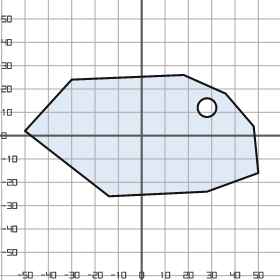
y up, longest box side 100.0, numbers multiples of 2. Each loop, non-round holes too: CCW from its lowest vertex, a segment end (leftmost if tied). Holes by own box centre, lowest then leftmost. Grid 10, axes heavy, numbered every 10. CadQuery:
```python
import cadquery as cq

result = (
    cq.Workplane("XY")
    .moveTo(-14.0, -26.0)
    .lineTo(28.0, -24.0)
    .lineTo(50.0, -16.0)
    .lineTo(48.0, 4.0)
    .lineTo(36.0, 18.0)
    .lineTo(18.0, 26.0)
    .lineTo(-30.0, 24.0)
    .lineTo(-50.0, 2.0)
    .close()
    .moveTo(28.0, 12.0)
    .circle(4.0)
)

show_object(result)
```